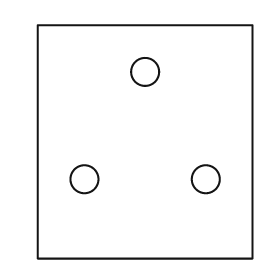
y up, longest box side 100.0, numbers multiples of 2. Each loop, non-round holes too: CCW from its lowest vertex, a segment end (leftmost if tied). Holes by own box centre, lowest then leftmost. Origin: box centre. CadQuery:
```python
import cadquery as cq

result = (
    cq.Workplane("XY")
    .moveTo(-46.0, -50.0)
    .lineTo(46.0, -50.0)
    .lineTo(46.0, 50.0)
    .lineTo(-46.0, 50.0)
    .close()
    .moveTo(-26.0, -16.0)
    .circle(6.0)
    .moveTo(26.0, -16.0)
    .circle(6.0)
    .moveTo(0.0, 30.0)
    .circle(6.0)
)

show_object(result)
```